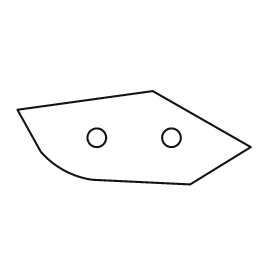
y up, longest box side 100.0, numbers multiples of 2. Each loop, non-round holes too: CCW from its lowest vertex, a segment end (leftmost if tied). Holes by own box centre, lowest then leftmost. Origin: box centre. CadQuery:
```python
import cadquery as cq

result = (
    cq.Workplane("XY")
    .moveTo(24.0, -20.0)
    .lineTo(50.0, -4.0)
    .lineTo(8.0, 20.0)
    .lineTo(-50.0, 12.0)
    .lineTo(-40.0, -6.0)
    .threePointArc((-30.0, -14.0), (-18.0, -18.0))
    .close()
    .moveTo(-16.0, 0.0)
    .circle(4.0)
    .moveTo(16.0, 0.0)
    .circle(4.0)
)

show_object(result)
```